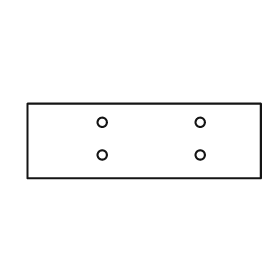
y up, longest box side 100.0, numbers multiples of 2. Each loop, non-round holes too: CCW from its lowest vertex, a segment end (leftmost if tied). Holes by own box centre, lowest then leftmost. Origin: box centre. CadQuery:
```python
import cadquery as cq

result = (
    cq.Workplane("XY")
    .moveTo(-50.0, -16.0)
    .lineTo(50.0, -16.0)
    .lineTo(50.0, 16.0)
    .lineTo(-50.0, 16.0)
    .close()
    .moveTo(-18.0, -6.0)
    .circle(2.0)
    .moveTo(24.0, -6.0)
    .circle(2.0)
    .moveTo(-18.0, 8.0)
    .circle(2.0)
    .moveTo(24.0, 8.0)
    .circle(2.0)
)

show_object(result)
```